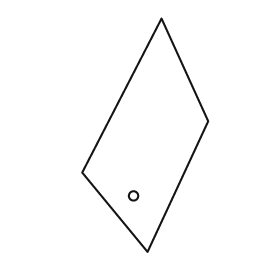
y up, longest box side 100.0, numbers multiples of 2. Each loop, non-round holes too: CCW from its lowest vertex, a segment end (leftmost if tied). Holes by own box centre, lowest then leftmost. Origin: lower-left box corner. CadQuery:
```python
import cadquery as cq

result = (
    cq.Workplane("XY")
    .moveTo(28.0, 0.0)
    .lineTo(54.0, 56.0)
    .lineTo(34.0, 100.0)
    .lineTo(0.0, 34.0)
    .close()
    .moveTo(22.0, 24.0)
    .circle(2.0)
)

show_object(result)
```